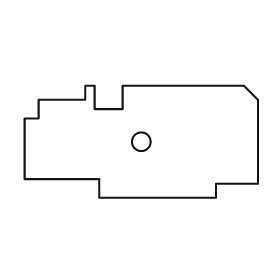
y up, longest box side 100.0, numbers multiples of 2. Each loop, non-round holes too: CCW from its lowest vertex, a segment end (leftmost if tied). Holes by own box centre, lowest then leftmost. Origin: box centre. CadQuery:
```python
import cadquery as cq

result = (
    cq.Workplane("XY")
    .moveTo(-18.0, -24.0)
    .lineTo(32.0, -24.0)
    .lineTo(32.0, -18.0)
    .lineTo(50.0, -18.0)
    .lineTo(50.0, 18.0)
    .lineTo(44.0, 24.0)
    .lineTo(-8.0, 24.0)
    .lineTo(-8.0, 14.0)
    .lineTo(-20.0, 14.0)
    .lineTo(-20.0, 24.0)
    .lineTo(-24.0, 24.0)
    .lineTo(-24.0, 18.0)
    .lineTo(-44.0, 18.0)
    .lineTo(-44.0, 10.0)
    .lineTo(-50.0, 10.0)
    .lineTo(-50.0, -16.0)
    .lineTo(-18.0, -16.0)
    .close()
    .moveTo(0.0, 0.0)
    .circle(4.0)
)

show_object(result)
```